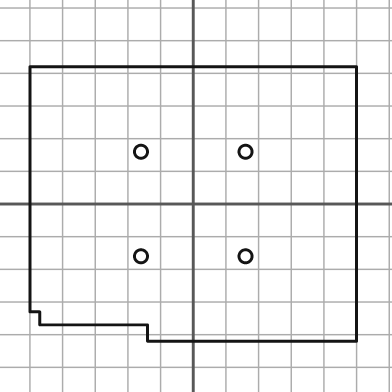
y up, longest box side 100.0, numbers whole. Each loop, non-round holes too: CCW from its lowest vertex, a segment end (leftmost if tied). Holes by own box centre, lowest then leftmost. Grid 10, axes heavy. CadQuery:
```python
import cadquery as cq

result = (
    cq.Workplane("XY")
    .moveTo(-14.0, -42.0)
    .lineTo(50.0, -42.0)
    .lineTo(50.0, 42.0)
    .lineTo(-50.0, 42.0)
    .lineTo(-50.0, -33.0)
    .lineTo(-47.0, -33.0)
    .lineTo(-47.0, -37.0)
    .lineTo(-14.0, -37.0)
    .close()
    .moveTo(-16.0, -16.0)
    .circle(2.0)
    .moveTo(16.0, -16.0)
    .circle(2.0)
    .moveTo(-16.0, 16.0)
    .circle(2.0)
    .moveTo(16.0, 16.0)
    .circle(2.0)
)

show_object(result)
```